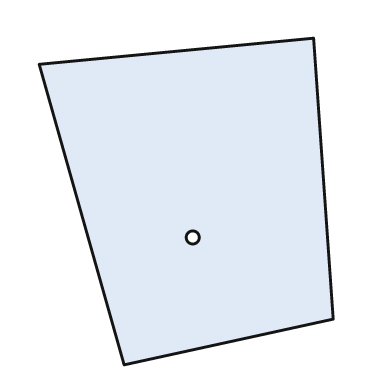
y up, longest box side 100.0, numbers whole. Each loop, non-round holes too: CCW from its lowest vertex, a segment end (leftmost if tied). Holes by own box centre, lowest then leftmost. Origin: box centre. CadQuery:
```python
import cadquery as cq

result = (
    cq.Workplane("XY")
    .moveTo(-19.0, -50.0)
    .lineTo(45.0, -36.0)
    .lineTo(39.0, 50.0)
    .lineTo(-45.0, 42.0)
    .close()
    .moveTo(2.0, -11.0)
    .circle(2.0)
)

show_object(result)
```